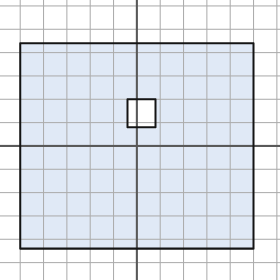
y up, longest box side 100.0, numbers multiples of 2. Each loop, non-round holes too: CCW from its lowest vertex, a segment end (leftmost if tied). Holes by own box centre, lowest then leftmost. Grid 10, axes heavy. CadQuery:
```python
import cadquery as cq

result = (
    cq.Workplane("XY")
    .moveTo(-50.0, -44.0)
    .lineTo(50.0, -44.0)
    .lineTo(50.0, 44.0)
    .lineTo(-50.0, 44.0)
    .close()
    .moveTo(-4.0, 8.0)
    .lineTo(8.0, 8.0)
    .lineTo(8.0, 20.0)
    .lineTo(-4.0, 20.0)
    .close()
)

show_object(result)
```